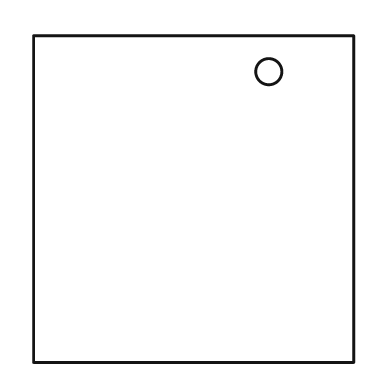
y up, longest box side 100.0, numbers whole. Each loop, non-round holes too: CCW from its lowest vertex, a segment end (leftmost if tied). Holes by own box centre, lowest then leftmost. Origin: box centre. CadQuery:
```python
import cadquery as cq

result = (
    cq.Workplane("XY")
    .moveTo(-49.0, -50.0)
    .lineTo(49.0, -50.0)
    .lineTo(49.0, 50.0)
    .lineTo(-49.0, 50.0)
    .close()
    .moveTo(23.0, 39.0)
    .circle(4.0)
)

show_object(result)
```